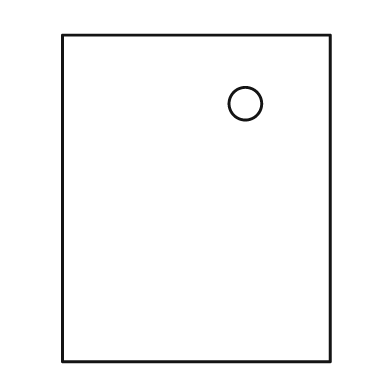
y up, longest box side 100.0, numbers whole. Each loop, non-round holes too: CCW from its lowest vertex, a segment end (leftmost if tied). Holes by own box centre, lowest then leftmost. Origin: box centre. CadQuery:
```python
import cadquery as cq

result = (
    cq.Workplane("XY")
    .moveTo(-41.0, -50.0)
    .lineTo(41.0, -50.0)
    .lineTo(41.0, 50.0)
    .lineTo(-41.0, 50.0)
    .close()
    .moveTo(15.0, 29.0)
    .circle(5.0)
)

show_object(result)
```